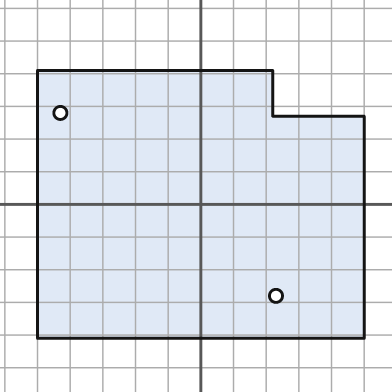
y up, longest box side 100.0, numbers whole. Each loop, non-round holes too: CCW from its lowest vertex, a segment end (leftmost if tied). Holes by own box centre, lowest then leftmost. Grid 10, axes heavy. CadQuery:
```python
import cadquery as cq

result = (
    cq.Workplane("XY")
    .moveTo(-50.0, -41.0)
    .lineTo(50.0, -41.0)
    .lineTo(50.0, 27.0)
    .lineTo(22.0, 27.0)
    .lineTo(22.0, 41.0)
    .lineTo(-50.0, 41.0)
    .close()
    .moveTo(23.0, -28.0)
    .circle(2.0)
    .moveTo(-43.0, 28.0)
    .circle(2.0)
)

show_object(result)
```